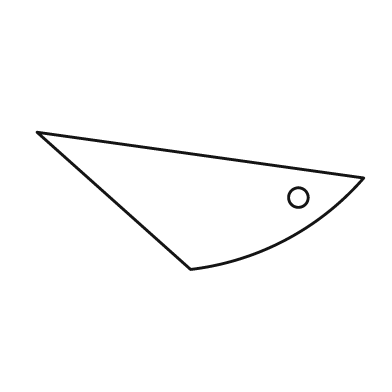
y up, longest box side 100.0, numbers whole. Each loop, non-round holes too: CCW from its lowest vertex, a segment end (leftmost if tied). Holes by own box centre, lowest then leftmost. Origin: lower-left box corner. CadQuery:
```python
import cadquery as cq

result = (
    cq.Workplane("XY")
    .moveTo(47.0, 0.0)
    .threePointArc((76.0, 9.0), (100.0, 28.0))
    .lineTo(0.0, 42.0)
    .close()
    .moveTo(80.0, 22.0)
    .circle(3.0)
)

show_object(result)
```